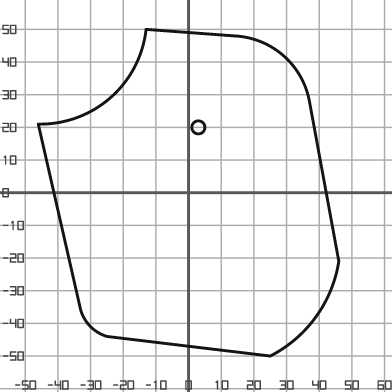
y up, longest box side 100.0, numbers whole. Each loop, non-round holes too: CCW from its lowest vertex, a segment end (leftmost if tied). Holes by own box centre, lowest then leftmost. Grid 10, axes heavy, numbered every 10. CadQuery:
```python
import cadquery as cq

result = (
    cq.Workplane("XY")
    .moveTo(25.0, -50.0)
    .threePointArc((39.0, -38.0), (46.0, -21.0))
    .lineTo(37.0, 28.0)
    .threePointArc((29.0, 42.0), (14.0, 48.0))
    .lineTo(-13.0, 50.0)
    .threePointArc((-24.0, 29.0), (-46.0, 21.0))
    .lineTo(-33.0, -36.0)
    .threePointArc((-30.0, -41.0), (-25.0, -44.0))
    .close()
    .moveTo(3.0, 20.0)
    .circle(2.0)
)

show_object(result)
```